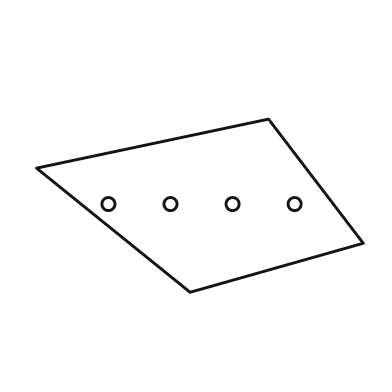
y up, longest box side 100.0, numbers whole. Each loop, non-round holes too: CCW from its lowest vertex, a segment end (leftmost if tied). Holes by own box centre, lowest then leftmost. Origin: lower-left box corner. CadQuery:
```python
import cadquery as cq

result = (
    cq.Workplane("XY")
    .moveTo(47.0, 0.0)
    .lineTo(100.0, 15.0)
    .lineTo(71.0, 53.0)
    .lineTo(0.0, 38.0)
    .close()
    .moveTo(22.0, 27.0)
    .circle(2.0)
    .moveTo(41.0, 27.0)
    .circle(2.0)
    .moveTo(60.0, 27.0)
    .circle(2.0)
    .moveTo(79.0, 27.0)
    .circle(2.0)
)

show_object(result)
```